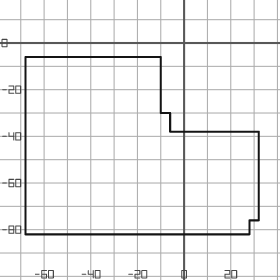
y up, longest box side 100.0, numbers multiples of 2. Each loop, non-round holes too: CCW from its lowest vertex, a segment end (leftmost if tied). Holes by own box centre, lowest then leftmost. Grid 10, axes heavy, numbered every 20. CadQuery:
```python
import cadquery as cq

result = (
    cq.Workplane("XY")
    .moveTo(-68.0, -82.0)
    .lineTo(28.0, -82.0)
    .lineTo(28.0, -76.0)
    .lineTo(32.0, -76.0)
    .lineTo(32.0, -38.0)
    .lineTo(-6.0, -38.0)
    .lineTo(-6.0, -30.0)
    .lineTo(-10.0, -30.0)
    .lineTo(-10.0, -6.0)
    .lineTo(-68.0, -6.0)
    .close()
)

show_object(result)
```